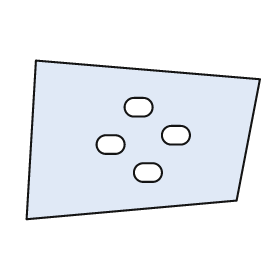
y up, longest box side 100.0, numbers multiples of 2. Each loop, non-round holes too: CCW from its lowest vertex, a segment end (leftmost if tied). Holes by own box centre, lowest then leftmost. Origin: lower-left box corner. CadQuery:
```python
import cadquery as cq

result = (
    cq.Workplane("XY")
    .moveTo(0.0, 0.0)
    .lineTo(90.0, 8.0)
    .lineTo(100.0, 60.0)
    .lineTo(4.0, 68.0)
    .close()
    .moveTo(50.0, 16.0)
    .lineTo(54.0, 16.0)
    .threePointArc((58.0, 20.0), (54.0, 24.0))
    .lineTo(50.0, 24.0)
    .threePointArc((46.0, 20.0), (50.0, 16.0))
    .close()
    .moveTo(34.0, 28.0)
    .lineTo(38.0, 28.0)
    .threePointArc((42.0, 32.0), (38.0, 36.0))
    .lineTo(34.0, 36.0)
    .threePointArc((30.0, 32.0), (34.0, 28.0))
    .close()
    .moveTo(62.0, 32.0)
    .lineTo(66.0, 32.0)
    .threePointArc((70.0, 36.0), (66.0, 40.0))
    .lineTo(62.0, 40.0)
    .threePointArc((58.0, 36.0), (62.0, 32.0))
    .close()
    .moveTo(46.0, 44.0)
    .lineTo(50.0, 44.0)
    .threePointArc((54.0, 48.0), (50.0, 52.0))
    .lineTo(46.0, 52.0)
    .threePointArc((42.0, 48.0), (46.0, 44.0))
    .close()
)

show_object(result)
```